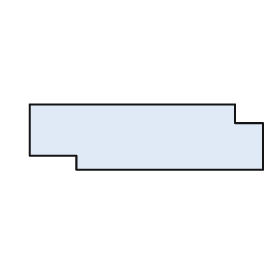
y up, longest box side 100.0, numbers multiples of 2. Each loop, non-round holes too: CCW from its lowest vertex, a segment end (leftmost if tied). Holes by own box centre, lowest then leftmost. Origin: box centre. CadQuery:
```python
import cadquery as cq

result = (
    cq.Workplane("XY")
    .moveTo(-30.0, -14.0)
    .lineTo(50.0, -14.0)
    .lineTo(50.0, 6.0)
    .lineTo(38.0, 6.0)
    .lineTo(38.0, 14.0)
    .lineTo(-50.0, 14.0)
    .lineTo(-50.0, -8.0)
    .lineTo(-30.0, -8.0)
    .close()
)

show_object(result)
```